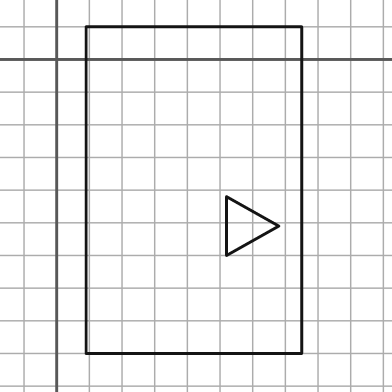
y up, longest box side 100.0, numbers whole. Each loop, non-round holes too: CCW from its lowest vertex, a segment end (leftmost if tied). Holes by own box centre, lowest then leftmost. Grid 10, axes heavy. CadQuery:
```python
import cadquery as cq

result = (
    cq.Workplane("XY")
    .moveTo(9.0, -90.0)
    .lineTo(75.0, -90.0)
    .lineTo(75.0, 10.0)
    .lineTo(9.0, 10.0)
    .close()
    .moveTo(52.0, -60.0)
    .lineTo(68.0, -51.0)
    .lineTo(52.0, -42.0)
    .close()
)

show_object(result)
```